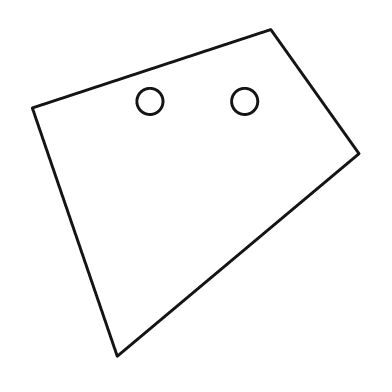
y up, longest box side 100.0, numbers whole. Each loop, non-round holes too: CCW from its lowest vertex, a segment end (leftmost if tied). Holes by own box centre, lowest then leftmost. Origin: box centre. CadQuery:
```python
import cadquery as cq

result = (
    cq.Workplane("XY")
    .moveTo(-24.0, -50.0)
    .lineTo(50.0, 12.0)
    .lineTo(23.0, 50.0)
    .lineTo(-50.0, 26.0)
    .close()
    .moveTo(-14.0, 28.0)
    .circle(4.0)
    .moveTo(15.0, 28.0)
    .circle(4.0)
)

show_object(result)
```